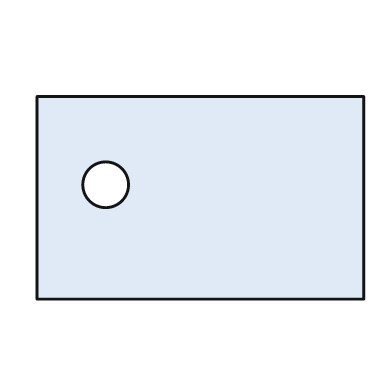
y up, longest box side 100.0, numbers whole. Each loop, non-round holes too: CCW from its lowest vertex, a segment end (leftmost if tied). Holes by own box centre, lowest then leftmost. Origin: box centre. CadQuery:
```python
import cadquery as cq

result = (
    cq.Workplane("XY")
    .moveTo(-50.0, -31.0)
    .lineTo(50.0, -31.0)
    .lineTo(50.0, 31.0)
    .lineTo(-50.0, 31.0)
    .close()
    .moveTo(-29.0, 4.0)
    .circle(7.0)
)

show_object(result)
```